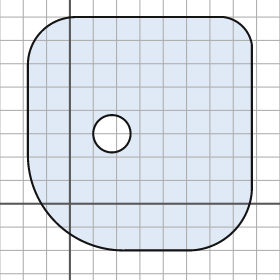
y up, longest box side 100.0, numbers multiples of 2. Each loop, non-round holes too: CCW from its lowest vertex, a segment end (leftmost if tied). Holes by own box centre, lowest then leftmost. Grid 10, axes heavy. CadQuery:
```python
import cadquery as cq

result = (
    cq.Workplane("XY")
    .moveTo(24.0, -20.0)
    .lineTo(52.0, -20.0)
    .threePointArc((70.0, -12.0), (78.0, 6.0))
    .lineTo(78.0, 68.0)
    .threePointArc((74.0, 76.0), (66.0, 80.0))
    .lineTo(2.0, 80.0)
    .threePointArc((-12.0, 74.0), (-18.0, 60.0))
    .lineTo(-18.0, 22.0)
    .threePointArc((-6.0, -8.0), (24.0, -20.0))
    .close()
    .moveTo(18.0, 30.0)
    .circle(8.0)
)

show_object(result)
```